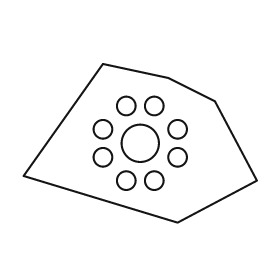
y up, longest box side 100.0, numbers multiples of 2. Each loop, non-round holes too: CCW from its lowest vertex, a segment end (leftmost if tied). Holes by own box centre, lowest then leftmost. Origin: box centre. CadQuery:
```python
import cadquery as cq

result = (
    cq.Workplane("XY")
    .moveTo(16.0, -34.0)
    .lineTo(50.0, -16.0)
    .lineTo(32.0, 18.0)
    .lineTo(12.0, 28.0)
    .lineTo(-16.0, 34.0)
    .lineTo(-50.0, -14.0)
    .close()
    .moveTo(-6.0, -16.0)
    .circle(4.0)
    .moveTo(6.0, -16.0)
    .circle(4.0)
    .moveTo(-16.0, -6.0)
    .circle(4.0)
    .moveTo(16.0, -6.0)
    .circle(4.0)
    .moveTo(0.0, 0.0)
    .circle(8.0)
    .moveTo(-16.0, 6.0)
    .circle(4.0)
    .moveTo(16.0, 6.0)
    .circle(4.0)
    .moveTo(-6.0, 16.0)
    .circle(4.0)
    .moveTo(6.0, 16.0)
    .circle(4.0)
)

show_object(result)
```